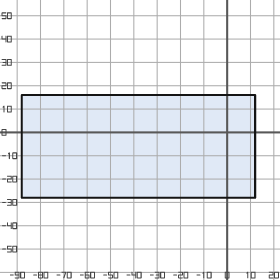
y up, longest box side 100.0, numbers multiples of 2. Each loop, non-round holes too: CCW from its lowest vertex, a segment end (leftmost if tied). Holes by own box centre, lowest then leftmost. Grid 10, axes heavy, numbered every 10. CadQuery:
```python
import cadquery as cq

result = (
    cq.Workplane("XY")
    .moveTo(-88.0, -28.0)
    .lineTo(12.0, -28.0)
    .lineTo(12.0, 16.0)
    .lineTo(-88.0, 16.0)
    .close()
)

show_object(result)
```